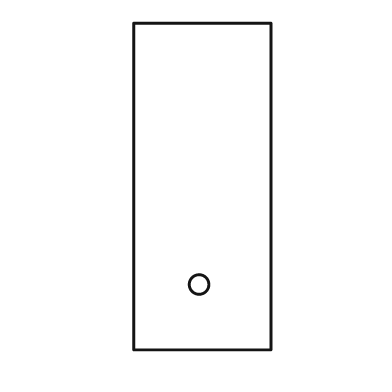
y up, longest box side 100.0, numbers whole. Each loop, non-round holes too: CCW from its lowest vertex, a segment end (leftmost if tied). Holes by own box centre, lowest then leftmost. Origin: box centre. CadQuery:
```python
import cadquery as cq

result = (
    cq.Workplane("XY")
    .moveTo(-21.0, -50.0)
    .lineTo(21.0, -50.0)
    .lineTo(21.0, 50.0)
    .lineTo(-21.0, 50.0)
    .close()
    .moveTo(-1.0, -30.0)
    .circle(3.0)
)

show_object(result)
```